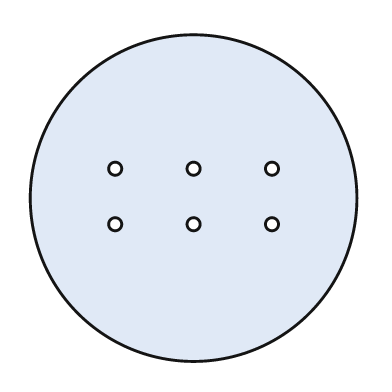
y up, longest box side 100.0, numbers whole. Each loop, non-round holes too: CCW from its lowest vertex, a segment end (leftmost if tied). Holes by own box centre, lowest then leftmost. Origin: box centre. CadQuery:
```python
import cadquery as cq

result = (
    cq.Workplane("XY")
    .moveTo(0.0, 0.0)
    .circle(50.0)
    .moveTo(-24.0, -8.0)
    .circle(2.0)
    .moveTo(0.0, -8.0)
    .circle(2.0)
    .moveTo(24.0, -8.0)
    .circle(2.0)
    .moveTo(-24.0, 9.0)
    .circle(2.0)
    .moveTo(0.0, 9.0)
    .circle(2.0)
    .moveTo(24.0, 9.0)
    .circle(2.0)
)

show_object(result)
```